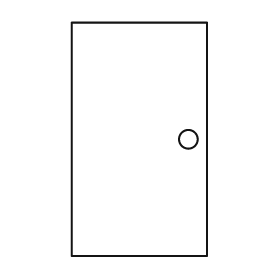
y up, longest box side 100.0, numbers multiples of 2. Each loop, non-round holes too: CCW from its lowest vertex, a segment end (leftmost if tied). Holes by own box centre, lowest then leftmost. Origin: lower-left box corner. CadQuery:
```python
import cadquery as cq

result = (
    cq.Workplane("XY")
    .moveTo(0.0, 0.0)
    .lineTo(58.0, 0.0)
    .lineTo(58.0, 100.0)
    .lineTo(0.0, 100.0)
    .close()
    .moveTo(50.0, 50.0)
    .circle(4.0)
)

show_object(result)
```